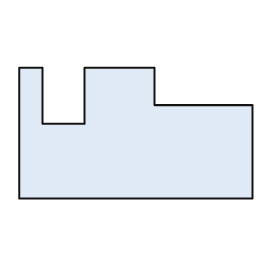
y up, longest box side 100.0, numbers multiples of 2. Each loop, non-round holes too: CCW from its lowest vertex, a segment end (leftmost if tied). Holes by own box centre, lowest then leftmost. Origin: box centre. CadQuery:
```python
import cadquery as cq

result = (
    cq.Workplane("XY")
    .moveTo(-50.0, -28.0)
    .lineTo(50.0, -28.0)
    .lineTo(50.0, 12.0)
    .lineTo(8.0, 12.0)
    .lineTo(8.0, 28.0)
    .lineTo(-22.0, 28.0)
    .lineTo(-22.0, 4.0)
    .lineTo(-40.0, 4.0)
    .lineTo(-40.0, 28.0)
    .lineTo(-50.0, 28.0)
    .close()
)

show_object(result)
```